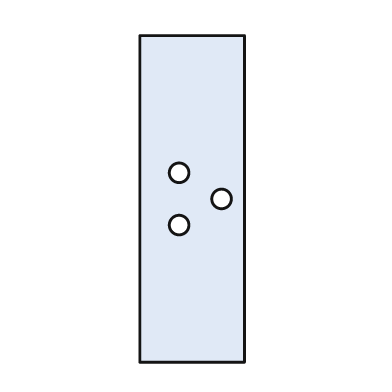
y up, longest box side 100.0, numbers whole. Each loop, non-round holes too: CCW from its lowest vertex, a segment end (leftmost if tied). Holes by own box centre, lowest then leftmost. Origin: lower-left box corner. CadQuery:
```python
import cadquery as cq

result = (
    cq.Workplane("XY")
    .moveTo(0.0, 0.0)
    .lineTo(32.0, 0.0)
    .lineTo(32.0, 100.0)
    .lineTo(0.0, 100.0)
    .close()
    .moveTo(12.0, 42.0)
    .circle(3.0)
    .moveTo(25.0, 50.0)
    .circle(3.0)
    .moveTo(12.0, 58.0)
    .circle(3.0)
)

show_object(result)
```